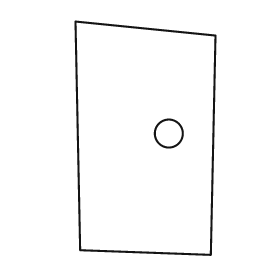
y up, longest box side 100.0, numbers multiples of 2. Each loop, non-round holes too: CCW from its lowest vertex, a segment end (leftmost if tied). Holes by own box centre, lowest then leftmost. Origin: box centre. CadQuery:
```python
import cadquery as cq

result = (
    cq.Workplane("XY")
    .moveTo(28.0, -50.0)
    .lineTo(30.0, 44.0)
    .lineTo(-30.0, 50.0)
    .lineTo(-28.0, -48.0)
    .close()
    .moveTo(10.0, 2.0)
    .circle(6.0)
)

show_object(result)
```